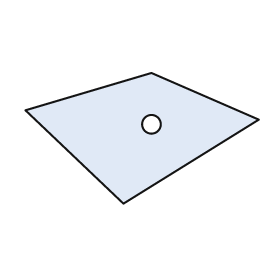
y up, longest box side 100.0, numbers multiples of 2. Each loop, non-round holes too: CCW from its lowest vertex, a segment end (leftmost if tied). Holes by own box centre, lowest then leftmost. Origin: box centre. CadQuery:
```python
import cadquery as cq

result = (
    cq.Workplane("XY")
    .moveTo(-8.0, -28.0)
    .lineTo(50.0, 8.0)
    .lineTo(4.0, 28.0)
    .lineTo(-50.0, 12.0)
    .close()
    .moveTo(4.0, 6.0)
    .circle(4.0)
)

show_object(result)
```